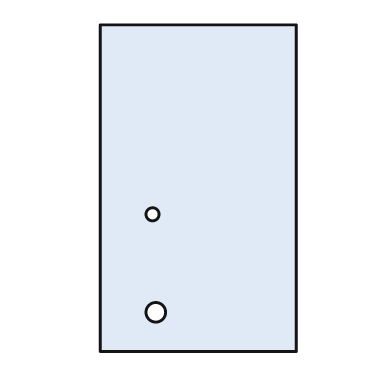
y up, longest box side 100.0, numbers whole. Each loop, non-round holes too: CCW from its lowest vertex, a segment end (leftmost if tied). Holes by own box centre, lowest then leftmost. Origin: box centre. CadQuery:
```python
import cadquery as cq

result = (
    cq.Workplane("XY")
    .moveTo(-30.0, -50.0)
    .lineTo(30.0, -50.0)
    .lineTo(30.0, 50.0)
    .lineTo(-30.0, 50.0)
    .close()
    .moveTo(-13.0, -38.0)
    .circle(3.0)
    .moveTo(-14.0, -8.0)
    .circle(2.0)
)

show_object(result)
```